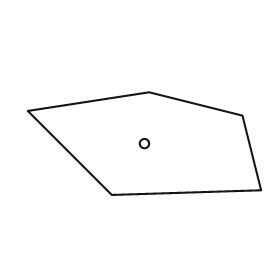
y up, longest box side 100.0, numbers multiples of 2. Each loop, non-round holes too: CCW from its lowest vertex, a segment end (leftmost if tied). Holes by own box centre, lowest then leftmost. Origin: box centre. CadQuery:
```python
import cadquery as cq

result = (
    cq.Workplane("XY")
    .moveTo(-14.0, -22.0)
    .lineTo(50.0, -20.0)
    .lineTo(42.0, 12.0)
    .lineTo(2.0, 22.0)
    .lineTo(-50.0, 14.0)
    .close()
    .moveTo(0.0, 0.0)
    .circle(2.0)
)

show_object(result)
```